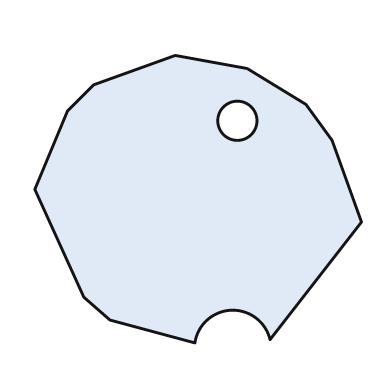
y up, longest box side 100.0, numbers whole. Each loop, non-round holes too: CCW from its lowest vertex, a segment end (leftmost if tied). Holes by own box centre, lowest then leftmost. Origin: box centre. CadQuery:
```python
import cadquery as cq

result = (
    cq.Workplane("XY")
    .moveTo(-1.0, -44.0)
    .threePointArc((10.0, -34.0), (22.0, -43.0))
    .lineTo(50.0, -7.0)
    .lineTo(41.0, 18.0)
    .lineTo(33.0, 29.0)
    .lineTo(15.0, 40.0)
    .lineTo(-7.0, 44.0)
    .lineTo(-32.0, 35.0)
    .lineTo(-40.0, 27.0)
    .lineTo(-50.0, 3.0)
    .lineTo(-35.0, -30.0)
    .lineTo(-27.0, -37.0)
    .close()
    .moveTo(12.0, 24.0)
    .circle(6.0)
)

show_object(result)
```